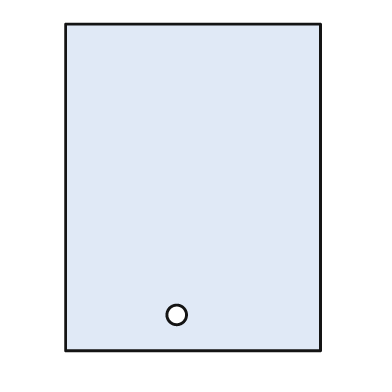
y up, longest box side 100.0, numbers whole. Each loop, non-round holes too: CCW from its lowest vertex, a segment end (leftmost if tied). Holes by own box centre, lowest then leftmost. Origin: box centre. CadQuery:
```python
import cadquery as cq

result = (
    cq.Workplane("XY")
    .moveTo(-39.0, -50.0)
    .lineTo(39.0, -50.0)
    .lineTo(39.0, 50.0)
    .lineTo(-39.0, 50.0)
    .close()
    .moveTo(-5.0, -39.0)
    .circle(3.0)
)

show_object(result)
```